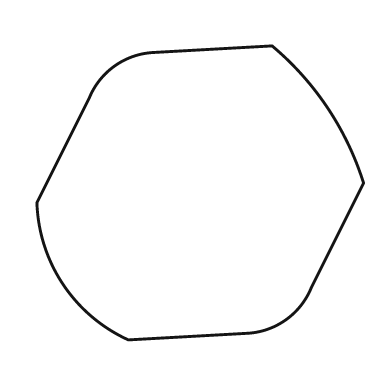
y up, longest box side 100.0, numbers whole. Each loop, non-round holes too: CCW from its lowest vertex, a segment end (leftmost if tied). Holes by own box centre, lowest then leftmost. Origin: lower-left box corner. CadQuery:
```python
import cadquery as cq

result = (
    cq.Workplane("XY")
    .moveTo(28.0, 0.0)
    .lineTo(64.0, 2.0)
    .threePointArc((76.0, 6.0), (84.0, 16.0))
    .lineTo(100.0, 48.0)
    .threePointArc((89.0, 71.0), (72.0, 90.0))
    .lineTo(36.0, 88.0)
    .threePointArc((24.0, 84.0), (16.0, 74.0))
    .lineTo(0.0, 42.0)
    .threePointArc((8.0, 17.0), (28.0, 0.0))
    .close()
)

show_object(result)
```